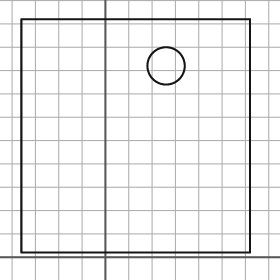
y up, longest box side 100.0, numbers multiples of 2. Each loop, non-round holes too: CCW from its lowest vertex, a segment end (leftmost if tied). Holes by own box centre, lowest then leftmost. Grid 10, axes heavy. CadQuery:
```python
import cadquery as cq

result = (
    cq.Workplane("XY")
    .moveTo(-36.0, 2.0)
    .lineTo(62.0, 2.0)
    .lineTo(62.0, 102.0)
    .lineTo(-36.0, 102.0)
    .close()
    .moveTo(26.0, 82.0)
    .circle(8.0)
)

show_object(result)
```